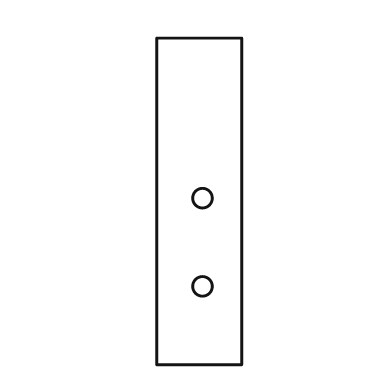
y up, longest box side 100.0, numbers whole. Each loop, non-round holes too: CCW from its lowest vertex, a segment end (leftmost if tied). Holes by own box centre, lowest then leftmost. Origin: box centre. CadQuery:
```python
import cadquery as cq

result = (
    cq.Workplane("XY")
    .moveTo(-13.0, -50.0)
    .lineTo(13.0, -50.0)
    .lineTo(13.0, 50.0)
    .lineTo(-13.0, 50.0)
    .close()
    .moveTo(1.0, -26.0)
    .circle(3.0)
    .moveTo(1.0, 1.0)
    .circle(3.0)
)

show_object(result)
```